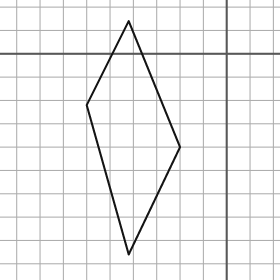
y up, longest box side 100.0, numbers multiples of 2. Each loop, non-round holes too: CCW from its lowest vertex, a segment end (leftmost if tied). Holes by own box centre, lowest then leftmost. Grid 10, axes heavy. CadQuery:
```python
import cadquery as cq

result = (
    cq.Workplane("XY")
    .moveTo(-42.0, -86.0)
    .lineTo(-20.0, -40.0)
    .lineTo(-42.0, 14.0)
    .lineTo(-60.0, -22.0)
    .close()
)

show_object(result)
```